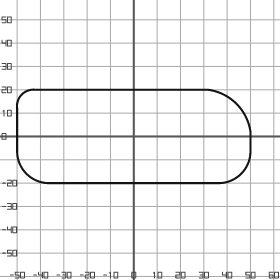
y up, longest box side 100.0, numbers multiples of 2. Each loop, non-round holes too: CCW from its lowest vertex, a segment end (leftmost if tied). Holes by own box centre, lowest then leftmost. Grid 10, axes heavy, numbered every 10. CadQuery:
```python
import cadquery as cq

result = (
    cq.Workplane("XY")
    .moveTo(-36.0, -20.0)
    .lineTo(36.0, -20.0)
    .threePointArc((46.0, -16.0), (50.0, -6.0))
    .lineTo(50.0, 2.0)
    .threePointArc((44.0, 14.0), (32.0, 20.0))
    .lineTo(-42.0, 20.0)
    .threePointArc((-48.0, 18.0), (-50.0, 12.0))
    .lineTo(-50.0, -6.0)
    .threePointArc((-46.0, -16.0), (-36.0, -20.0))
    .close()
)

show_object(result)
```